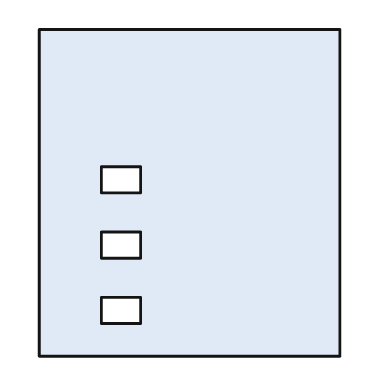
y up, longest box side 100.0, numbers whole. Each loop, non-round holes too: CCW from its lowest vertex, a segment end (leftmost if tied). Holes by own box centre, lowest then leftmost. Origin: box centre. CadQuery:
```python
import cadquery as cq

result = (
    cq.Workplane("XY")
    .moveTo(-46.0, -50.0)
    .lineTo(46.0, -50.0)
    .lineTo(46.0, 50.0)
    .lineTo(-46.0, 50.0)
    .close()
    .moveTo(-27.0, -40.0)
    .lineTo(-15.0, -40.0)
    .lineTo(-15.0, -32.0)
    .lineTo(-27.0, -32.0)
    .close()
    .moveTo(-27.0, -20.0)
    .lineTo(-15.0, -20.0)
    .lineTo(-15.0, -12.0)
    .lineTo(-27.0, -12.0)
    .close()
    .moveTo(-27.0, 0.0)
    .lineTo(-15.0, 0.0)
    .lineTo(-15.0, 8.0)
    .lineTo(-27.0, 8.0)
    .close()
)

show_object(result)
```